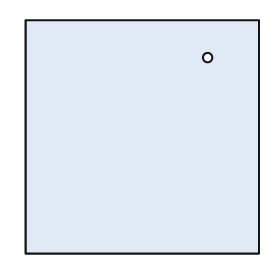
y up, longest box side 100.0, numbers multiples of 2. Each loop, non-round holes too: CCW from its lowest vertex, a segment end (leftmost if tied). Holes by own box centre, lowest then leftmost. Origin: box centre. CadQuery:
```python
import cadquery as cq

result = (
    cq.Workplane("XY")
    .moveTo(-50.0, -50.0)
    .lineTo(50.0, -50.0)
    .lineTo(50.0, 50.0)
    .lineTo(-50.0, 50.0)
    .close()
    .moveTo(28.0, 34.0)
    .circle(2.0)
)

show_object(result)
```